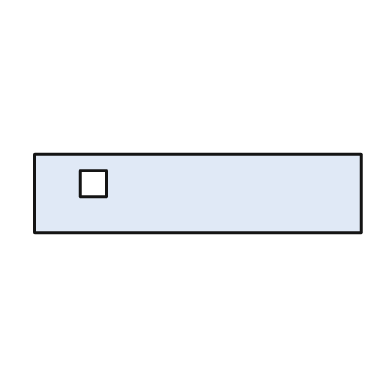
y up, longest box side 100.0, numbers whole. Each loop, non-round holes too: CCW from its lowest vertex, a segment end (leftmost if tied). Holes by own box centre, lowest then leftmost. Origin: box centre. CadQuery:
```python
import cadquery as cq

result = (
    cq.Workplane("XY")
    .moveTo(-50.0, -12.0)
    .lineTo(50.0, -12.0)
    .lineTo(50.0, 12.0)
    .lineTo(-50.0, 12.0)
    .close()
    .moveTo(-36.0, -1.0)
    .lineTo(-28.0, -1.0)
    .lineTo(-28.0, 7.0)
    .lineTo(-36.0, 7.0)
    .close()
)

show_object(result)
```